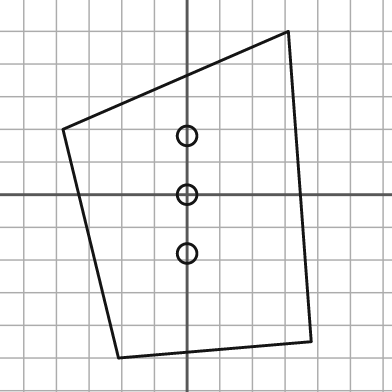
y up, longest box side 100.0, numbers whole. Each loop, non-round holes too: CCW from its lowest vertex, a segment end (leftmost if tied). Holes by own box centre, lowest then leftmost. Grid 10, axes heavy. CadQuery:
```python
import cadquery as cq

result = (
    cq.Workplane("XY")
    .moveTo(-21.0, -50.0)
    .lineTo(38.0, -45.0)
    .lineTo(31.0, 50.0)
    .lineTo(-38.0, 20.0)
    .close()
    .moveTo(0.0, -18.0)
    .circle(3.0)
    .moveTo(0.0, 0.0)
    .circle(3.0)
    .moveTo(0.0, 18.0)
    .circle(3.0)
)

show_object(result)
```